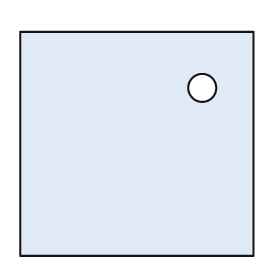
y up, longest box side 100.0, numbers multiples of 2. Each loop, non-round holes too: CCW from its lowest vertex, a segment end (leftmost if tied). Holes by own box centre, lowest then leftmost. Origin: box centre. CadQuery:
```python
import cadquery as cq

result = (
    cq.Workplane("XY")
    .moveTo(-50.0, -48.0)
    .lineTo(50.0, -48.0)
    .lineTo(50.0, 48.0)
    .lineTo(-50.0, 48.0)
    .close()
    .moveTo(28.0, 24.0)
    .circle(6.0)
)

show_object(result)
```